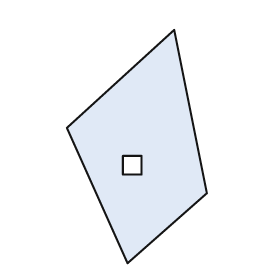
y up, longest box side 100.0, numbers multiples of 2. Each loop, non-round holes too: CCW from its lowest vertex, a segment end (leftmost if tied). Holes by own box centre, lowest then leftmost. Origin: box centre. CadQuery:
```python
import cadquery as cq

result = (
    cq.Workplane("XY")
    .moveTo(-4.0, -50.0)
    .lineTo(30.0, -20.0)
    .lineTo(16.0, 50.0)
    .lineTo(-30.0, 8.0)
    .close()
    .moveTo(-6.0, -12.0)
    .lineTo(2.0, -12.0)
    .lineTo(2.0, -4.0)
    .lineTo(-6.0, -4.0)
    .close()
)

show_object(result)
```